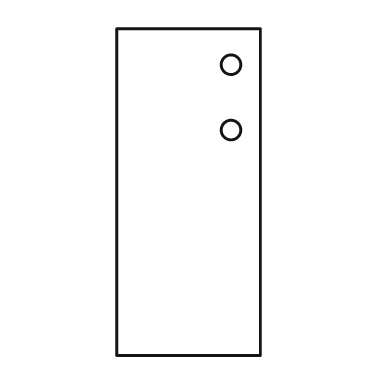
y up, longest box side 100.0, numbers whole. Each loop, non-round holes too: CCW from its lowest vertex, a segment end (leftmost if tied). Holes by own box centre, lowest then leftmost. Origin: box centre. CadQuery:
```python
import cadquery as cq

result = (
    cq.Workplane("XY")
    .moveTo(-22.0, -50.0)
    .lineTo(22.0, -50.0)
    .lineTo(22.0, 50.0)
    .lineTo(-22.0, 50.0)
    .close()
    .moveTo(13.0, 19.0)
    .circle(3.0)
    .moveTo(13.0, 39.0)
    .circle(3.0)
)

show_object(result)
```